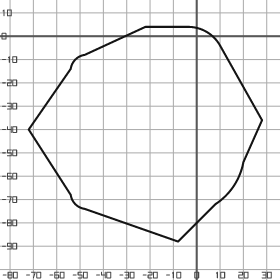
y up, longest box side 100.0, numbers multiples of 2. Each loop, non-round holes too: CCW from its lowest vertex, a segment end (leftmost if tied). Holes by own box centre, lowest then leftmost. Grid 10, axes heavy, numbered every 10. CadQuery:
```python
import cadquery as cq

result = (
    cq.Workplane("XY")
    .moveTo(-8.0, -88.0)
    .lineTo(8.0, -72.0)
    .threePointArc((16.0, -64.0), (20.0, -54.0))
    .lineTo(28.0, -36.0)
    .lineTo(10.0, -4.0)
    .threePointArc((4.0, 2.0), (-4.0, 4.0))
    .lineTo(-22.0, 4.0)
    .lineTo(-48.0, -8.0)
    .threePointArc((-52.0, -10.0), (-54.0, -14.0))
    .lineTo(-72.0, -40.0)
    .lineTo(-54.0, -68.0)
    .threePointArc((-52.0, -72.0), (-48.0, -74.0))
    .close()
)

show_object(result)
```